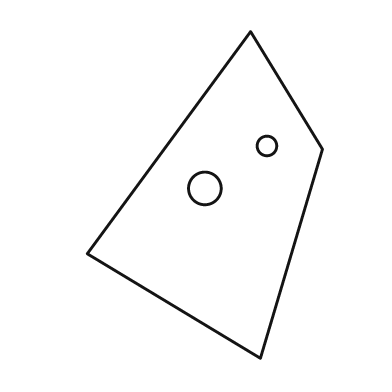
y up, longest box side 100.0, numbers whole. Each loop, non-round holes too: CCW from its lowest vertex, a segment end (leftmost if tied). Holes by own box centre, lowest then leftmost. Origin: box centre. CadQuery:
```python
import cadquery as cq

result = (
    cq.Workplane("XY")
    .moveTo(17.0, -50.0)
    .lineTo(36.0, 14.0)
    .lineTo(14.0, 50.0)
    .lineTo(-36.0, -18.0)
    .close()
    .moveTo(0.0, 2.0)
    .circle(5.0)
    .moveTo(19.0, 15.0)
    .circle(3.0)
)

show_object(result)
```